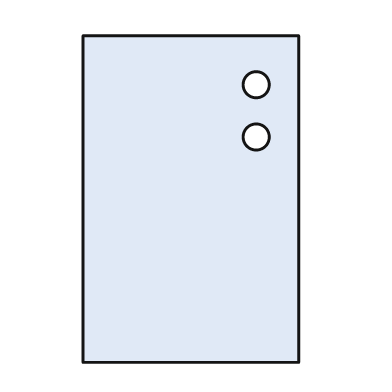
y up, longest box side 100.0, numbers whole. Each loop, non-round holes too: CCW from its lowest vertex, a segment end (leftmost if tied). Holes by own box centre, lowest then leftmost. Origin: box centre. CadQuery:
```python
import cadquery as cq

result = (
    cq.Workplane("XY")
    .moveTo(-33.0, -50.0)
    .lineTo(33.0, -50.0)
    .lineTo(33.0, 50.0)
    .lineTo(-33.0, 50.0)
    .close()
    .moveTo(20.0, 19.0)
    .circle(4.0)
    .moveTo(20.0, 35.0)
    .circle(4.0)
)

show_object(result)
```